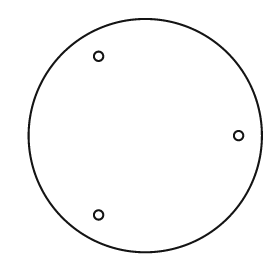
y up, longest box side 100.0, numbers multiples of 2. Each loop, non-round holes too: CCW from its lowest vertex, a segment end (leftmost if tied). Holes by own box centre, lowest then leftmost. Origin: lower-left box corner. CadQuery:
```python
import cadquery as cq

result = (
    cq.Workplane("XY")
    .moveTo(50.0, 50.0)
    .circle(50.0)
    .moveTo(30.0, 16.0)
    .circle(2.0)
    .moveTo(90.0, 50.0)
    .circle(2.0)
    .moveTo(30.0, 84.0)
    .circle(2.0)
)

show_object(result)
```